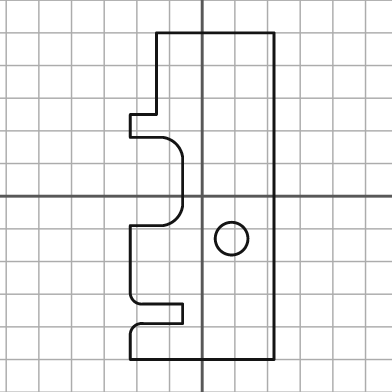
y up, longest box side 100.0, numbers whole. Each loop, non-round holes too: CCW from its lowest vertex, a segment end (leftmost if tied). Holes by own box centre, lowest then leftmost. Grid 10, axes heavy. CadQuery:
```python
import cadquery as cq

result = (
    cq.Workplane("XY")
    .moveTo(-22.0, -50.0)
    .lineTo(22.0, -50.0)
    .lineTo(22.0, 50.0)
    .lineTo(-14.0, 50.0)
    .lineTo(-14.0, 25.0)
    .lineTo(-22.0, 25.0)
    .lineTo(-22.0, 18.0)
    .lineTo(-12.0, 18.0)
    .threePointArc((-8.0, 16.0), (-6.0, 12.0))
    .lineTo(-6.0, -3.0)
    .threePointArc((-8.0, -7.0), (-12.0, -9.0))
    .lineTo(-22.0, -9.0)
    .lineTo(-22.0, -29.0)
    .threePointArc((-21.0, -32.0), (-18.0, -33.0))
    .lineTo(-6.0, -33.0)
    .lineTo(-6.0, -39.0)
    .lineTo(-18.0, -39.0)
    .threePointArc((-21.0, -40.0), (-22.0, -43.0))
    .close()
    .moveTo(9.0, -13.0)
    .circle(5.0)
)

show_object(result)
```